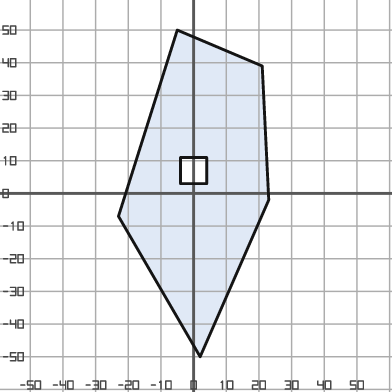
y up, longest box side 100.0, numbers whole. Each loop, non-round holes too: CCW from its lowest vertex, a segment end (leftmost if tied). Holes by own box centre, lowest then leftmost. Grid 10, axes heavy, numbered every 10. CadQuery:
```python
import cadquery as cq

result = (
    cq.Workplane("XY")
    .moveTo(2.0, -50.0)
    .lineTo(23.0, -2.0)
    .lineTo(21.0, 39.0)
    .lineTo(-5.0, 50.0)
    .lineTo(-23.0, -7.0)
    .close()
    .moveTo(-4.0, 3.0)
    .lineTo(4.0, 3.0)
    .lineTo(4.0, 11.0)
    .lineTo(-4.0, 11.0)
    .close()
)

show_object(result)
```